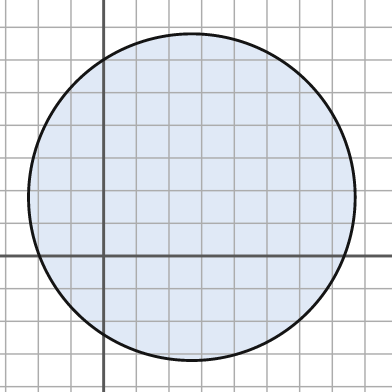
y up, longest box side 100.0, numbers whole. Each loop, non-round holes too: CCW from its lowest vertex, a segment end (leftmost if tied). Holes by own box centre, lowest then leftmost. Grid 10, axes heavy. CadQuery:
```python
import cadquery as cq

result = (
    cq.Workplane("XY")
    .moveTo(27.0, 18.0)
    .circle(50.0)
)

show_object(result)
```